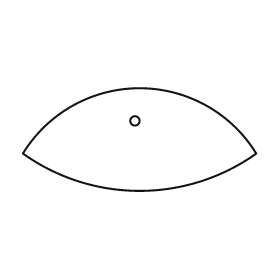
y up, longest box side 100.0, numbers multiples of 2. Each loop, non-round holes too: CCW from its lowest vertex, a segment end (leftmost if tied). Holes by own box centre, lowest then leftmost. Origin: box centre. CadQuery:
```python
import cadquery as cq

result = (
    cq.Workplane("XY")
    .moveTo(-50.0, -6.0)
    .threePointArc((0.0, -22.0), (50.0, -6.0))
    .threePointArc((0.0, 22.0), (-50.0, -6.0))
    .close()
    .moveTo(-2.0, 8.0)
    .circle(2.0)
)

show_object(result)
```